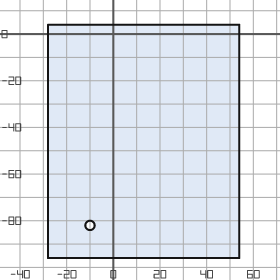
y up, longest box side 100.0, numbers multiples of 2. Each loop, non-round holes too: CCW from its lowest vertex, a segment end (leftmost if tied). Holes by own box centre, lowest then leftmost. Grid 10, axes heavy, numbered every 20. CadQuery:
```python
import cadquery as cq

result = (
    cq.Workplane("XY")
    .moveTo(-28.0, -96.0)
    .lineTo(54.0, -96.0)
    .lineTo(54.0, 4.0)
    .lineTo(-28.0, 4.0)
    .close()
    .moveTo(-10.0, -82.0)
    .circle(2.0)
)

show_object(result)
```